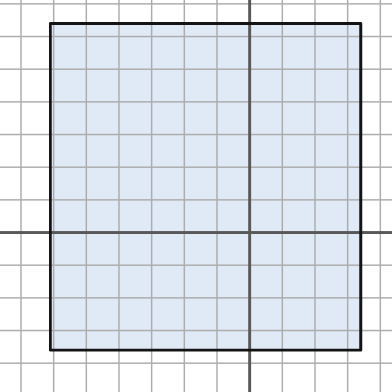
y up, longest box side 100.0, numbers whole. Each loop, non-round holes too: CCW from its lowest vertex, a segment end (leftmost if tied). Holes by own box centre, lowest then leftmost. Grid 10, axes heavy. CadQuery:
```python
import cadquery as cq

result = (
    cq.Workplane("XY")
    .moveTo(-61.0, -36.0)
    .lineTo(34.0, -36.0)
    .lineTo(34.0, 64.0)
    .lineTo(-61.0, 64.0)
    .close()
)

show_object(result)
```